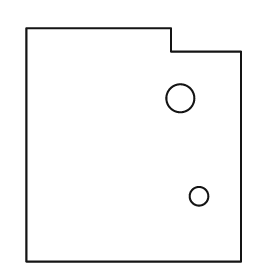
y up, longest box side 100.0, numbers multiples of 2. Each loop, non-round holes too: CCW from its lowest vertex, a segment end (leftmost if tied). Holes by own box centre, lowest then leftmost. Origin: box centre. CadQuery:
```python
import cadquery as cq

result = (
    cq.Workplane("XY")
    .moveTo(-46.0, -50.0)
    .lineTo(46.0, -50.0)
    .lineTo(46.0, 40.0)
    .lineTo(16.0, 40.0)
    .lineTo(16.0, 50.0)
    .lineTo(-46.0, 50.0)
    .close()
    .moveTo(28.0, -22.0)
    .circle(4.0)
    .moveTo(20.0, 20.0)
    .circle(6.0)
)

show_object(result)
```